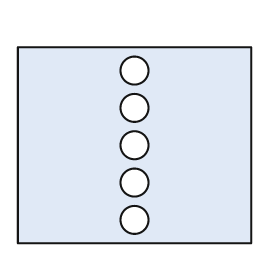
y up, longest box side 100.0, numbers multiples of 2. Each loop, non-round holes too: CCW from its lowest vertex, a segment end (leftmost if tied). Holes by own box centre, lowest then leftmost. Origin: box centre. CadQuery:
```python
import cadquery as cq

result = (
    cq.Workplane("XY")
    .moveTo(-50.0, -42.0)
    .lineTo(50.0, -42.0)
    .lineTo(50.0, 42.0)
    .lineTo(-50.0, 42.0)
    .close()
    .moveTo(0.0, -32.0)
    .circle(6.0)
    .moveTo(0.0, -16.0)
    .circle(6.0)
    .moveTo(0.0, 0.0)
    .circle(6.0)
    .moveTo(0.0, 16.0)
    .circle(6.0)
    .moveTo(0.0, 32.0)
    .circle(6.0)
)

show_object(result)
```